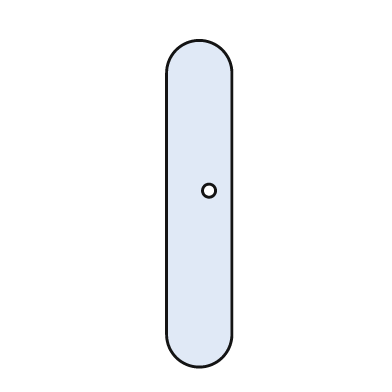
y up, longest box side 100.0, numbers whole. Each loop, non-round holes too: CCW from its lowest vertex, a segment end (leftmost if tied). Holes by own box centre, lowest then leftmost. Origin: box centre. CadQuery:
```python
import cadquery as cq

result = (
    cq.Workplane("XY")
    .moveTo(-10.0, -40.0)
    .threePointArc((0.0, -50.0), (10.0, -40.0))
    .lineTo(10.0, 40.0)
    .threePointArc((0.0, 50.0), (-10.0, 40.0))
    .close()
    .moveTo(3.0, 4.0)
    .circle(2.0)
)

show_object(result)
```